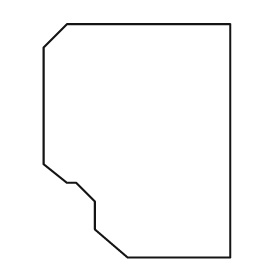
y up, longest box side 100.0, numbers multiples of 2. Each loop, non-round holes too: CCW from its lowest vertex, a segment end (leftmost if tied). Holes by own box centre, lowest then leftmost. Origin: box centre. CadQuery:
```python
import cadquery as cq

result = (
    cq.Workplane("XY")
    .moveTo(-4.0, -50.0)
    .lineTo(40.0, -50.0)
    .lineTo(40.0, 50.0)
    .lineTo(-30.0, 50.0)
    .lineTo(-40.0, 40.0)
    .lineTo(-40.0, -10.0)
    .lineTo(-30.0, -18.0)
    .lineTo(-26.0, -18.0)
    .lineTo(-18.0, -26.0)
    .lineTo(-18.0, -38.0)
    .close()
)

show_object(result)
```